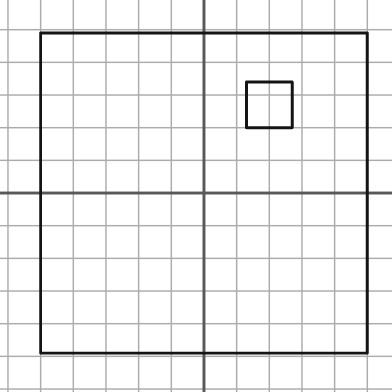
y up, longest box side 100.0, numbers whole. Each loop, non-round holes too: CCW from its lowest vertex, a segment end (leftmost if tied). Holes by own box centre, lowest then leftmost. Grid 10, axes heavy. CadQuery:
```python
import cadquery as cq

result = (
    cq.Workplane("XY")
    .moveTo(-50.0, -49.0)
    .lineTo(50.0, -49.0)
    .lineTo(50.0, 49.0)
    .lineTo(-50.0, 49.0)
    .close()
    .moveTo(13.0, 20.0)
    .lineTo(27.0, 20.0)
    .lineTo(27.0, 34.0)
    .lineTo(13.0, 34.0)
    .close()
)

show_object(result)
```